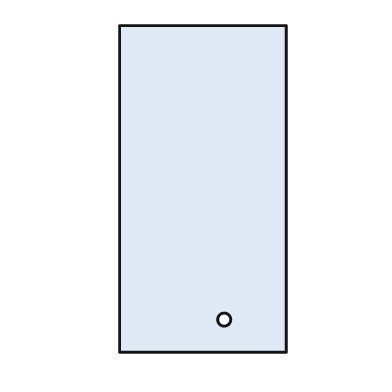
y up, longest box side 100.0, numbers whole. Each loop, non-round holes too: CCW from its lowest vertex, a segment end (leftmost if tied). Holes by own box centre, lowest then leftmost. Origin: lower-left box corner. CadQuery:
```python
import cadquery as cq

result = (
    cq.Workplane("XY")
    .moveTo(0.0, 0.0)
    .lineTo(51.0, 0.0)
    .lineTo(51.0, 100.0)
    .lineTo(0.0, 100.0)
    .close()
    .moveTo(32.0, 10.0)
    .circle(2.0)
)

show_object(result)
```